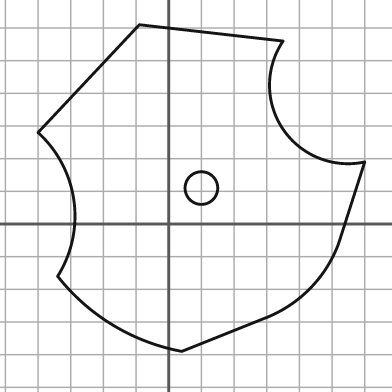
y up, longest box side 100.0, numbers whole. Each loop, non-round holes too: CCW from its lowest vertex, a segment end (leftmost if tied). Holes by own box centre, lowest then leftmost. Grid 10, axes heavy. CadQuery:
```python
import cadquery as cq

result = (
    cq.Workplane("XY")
    .moveTo(4.0, -39.0)
    .lineTo(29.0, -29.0)
    .threePointArc((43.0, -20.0), (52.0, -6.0))
    .lineTo(60.0, 19.0)
    .threePointArc((35.0, 29.0), (35.0, 56.0))
    .lineTo(-9.0, 61.0)
    .lineTo(-40.0, 28.0)
    .threePointArc((-29.0, 7.0), (-34.0, -16.0))
    .threePointArc((-17.0, -31.0), (4.0, -39.0))
    .close()
    .moveTo(10.0, 11.0)
    .circle(5.0)
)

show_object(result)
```